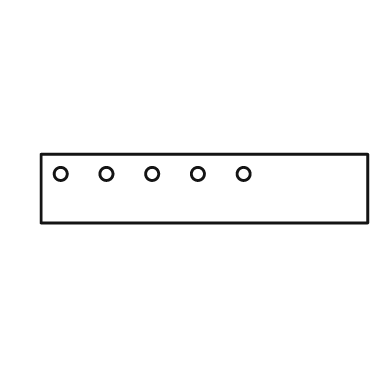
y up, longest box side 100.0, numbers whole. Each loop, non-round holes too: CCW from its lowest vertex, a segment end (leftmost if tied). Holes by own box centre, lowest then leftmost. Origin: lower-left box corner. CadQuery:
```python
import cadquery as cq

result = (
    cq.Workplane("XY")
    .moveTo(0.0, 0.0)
    .lineTo(100.0, 0.0)
    .lineTo(100.0, 21.0)
    .lineTo(0.0, 21.0)
    .close()
    .moveTo(6.0, 15.0)
    .circle(2.0)
    .moveTo(20.0, 15.0)
    .circle(2.0)
    .moveTo(34.0, 15.0)
    .circle(2.0)
    .moveTo(48.0, 15.0)
    .circle(2.0)
    .moveTo(62.0, 15.0)
    .circle(2.0)
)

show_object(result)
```